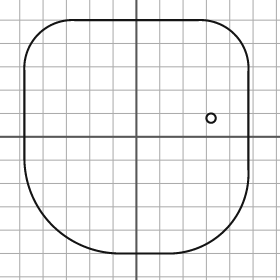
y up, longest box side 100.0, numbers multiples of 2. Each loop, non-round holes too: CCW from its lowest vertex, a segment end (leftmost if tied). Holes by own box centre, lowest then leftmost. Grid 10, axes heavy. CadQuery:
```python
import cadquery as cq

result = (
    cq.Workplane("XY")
    .moveTo(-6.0, -50.0)
    .lineTo(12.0, -50.0)
    .threePointArc((38.0, -40.0), (48.0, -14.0))
    .lineTo(48.0, 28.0)
    .threePointArc((42.0, 44.0), (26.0, 50.0))
    .lineTo(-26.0, 50.0)
    .threePointArc((-42.0, 44.0), (-48.0, 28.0))
    .lineTo(-48.0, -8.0)
    .threePointArc((-36.0, -38.0), (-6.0, -50.0))
    .close()
    .moveTo(32.0, 8.0)
    .circle(2.0)
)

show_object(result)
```